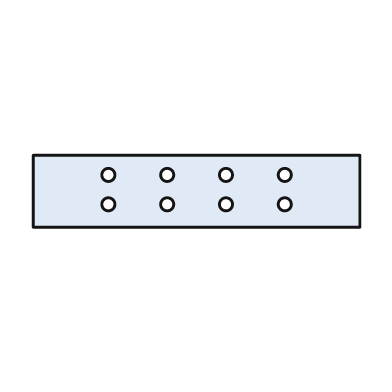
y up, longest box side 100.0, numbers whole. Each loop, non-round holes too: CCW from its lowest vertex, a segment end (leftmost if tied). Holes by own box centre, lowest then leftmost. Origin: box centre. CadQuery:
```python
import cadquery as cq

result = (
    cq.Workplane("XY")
    .moveTo(-50.0, -11.0)
    .lineTo(50.0, -11.0)
    .lineTo(50.0, 11.0)
    .lineTo(-50.0, 11.0)
    .close()
    .moveTo(-27.0, -4.0)
    .circle(2.0)
    .moveTo(-9.0, -4.0)
    .circle(2.0)
    .moveTo(9.0, -4.0)
    .circle(2.0)
    .moveTo(27.0, -4.0)
    .circle(2.0)
    .moveTo(-27.0, 5.0)
    .circle(2.0)
    .moveTo(-9.0, 5.0)
    .circle(2.0)
    .moveTo(9.0, 5.0)
    .circle(2.0)
    .moveTo(27.0, 5.0)
    .circle(2.0)
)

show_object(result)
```